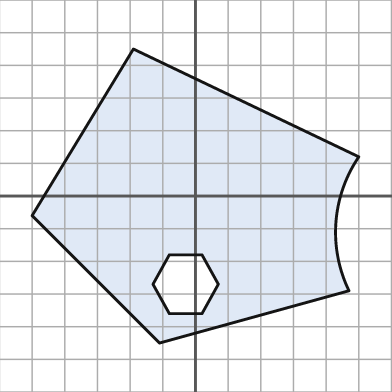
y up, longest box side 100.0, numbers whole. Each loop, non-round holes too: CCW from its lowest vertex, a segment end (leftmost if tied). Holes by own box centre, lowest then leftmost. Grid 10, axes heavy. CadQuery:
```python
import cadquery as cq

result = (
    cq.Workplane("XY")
    .moveTo(-11.0, -45.0)
    .lineTo(47.0, -29.0)
    .threePointArc((43.0, -8.0), (50.0, 12.0))
    .lineTo(-19.0, 45.0)
    .lineTo(-50.0, -6.0)
    .close()
    .moveTo(-8.0, -36.0)
    .lineTo(2.0, -36.0)
    .lineTo(7.0, -27.0)
    .lineTo(2.0, -18.0)
    .lineTo(-8.0, -18.0)
    .lineTo(-13.0, -27.0)
    .close()
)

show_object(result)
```